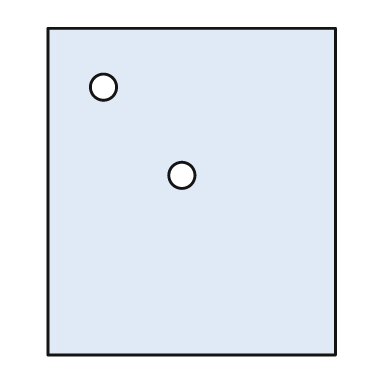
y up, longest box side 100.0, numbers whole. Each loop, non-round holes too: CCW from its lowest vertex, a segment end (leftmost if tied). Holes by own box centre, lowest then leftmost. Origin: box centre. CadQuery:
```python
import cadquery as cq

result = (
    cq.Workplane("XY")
    .moveTo(-44.0, -50.0)
    .lineTo(44.0, -50.0)
    .lineTo(44.0, 50.0)
    .lineTo(-44.0, 50.0)
    .close()
    .moveTo(-3.0, 5.0)
    .circle(4.0)
    .moveTo(-27.0, 32.0)
    .circle(4.0)
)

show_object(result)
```